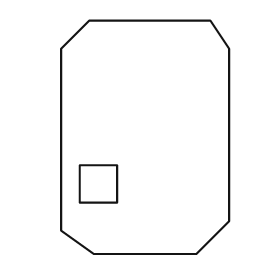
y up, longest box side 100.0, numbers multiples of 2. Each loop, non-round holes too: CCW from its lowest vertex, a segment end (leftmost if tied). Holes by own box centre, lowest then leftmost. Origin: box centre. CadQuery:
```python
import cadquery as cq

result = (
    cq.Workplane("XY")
    .moveTo(-22.0, -50.0)
    .lineTo(22.0, -50.0)
    .lineTo(36.0, -36.0)
    .lineTo(36.0, 38.0)
    .lineTo(28.0, 50.0)
    .lineTo(-24.0, 50.0)
    .lineTo(-36.0, 38.0)
    .lineTo(-36.0, -40.0)
    .close()
    .moveTo(-28.0, -28.0)
    .lineTo(-12.0, -28.0)
    .lineTo(-12.0, -12.0)
    .lineTo(-28.0, -12.0)
    .close()
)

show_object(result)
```